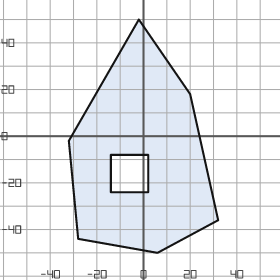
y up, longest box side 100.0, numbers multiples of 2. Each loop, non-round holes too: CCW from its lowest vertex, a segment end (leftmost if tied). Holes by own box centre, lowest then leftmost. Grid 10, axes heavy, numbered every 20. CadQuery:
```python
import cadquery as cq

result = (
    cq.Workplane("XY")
    .moveTo(6.0, -50.0)
    .lineTo(32.0, -36.0)
    .lineTo(20.0, 18.0)
    .lineTo(-2.0, 50.0)
    .lineTo(-32.0, -2.0)
    .lineTo(-28.0, -44.0)
    .close()
    .moveTo(-14.0, -24.0)
    .lineTo(2.0, -24.0)
    .lineTo(2.0, -8.0)
    .lineTo(-14.0, -8.0)
    .close()
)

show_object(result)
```